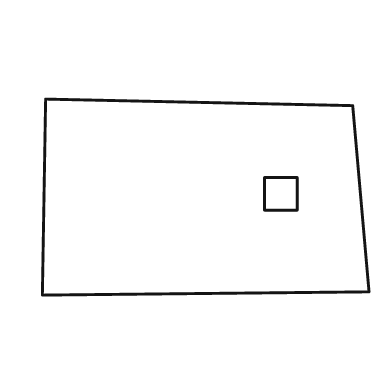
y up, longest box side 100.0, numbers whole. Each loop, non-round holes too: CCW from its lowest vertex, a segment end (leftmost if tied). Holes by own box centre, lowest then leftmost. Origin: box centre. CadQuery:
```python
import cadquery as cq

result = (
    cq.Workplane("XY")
    .moveTo(-50.0, -30.0)
    .lineTo(50.0, -29.0)
    .lineTo(45.0, 28.0)
    .lineTo(-49.0, 30.0)
    .close()
    .moveTo(18.0, -4.0)
    .lineTo(28.0, -4.0)
    .lineTo(28.0, 6.0)
    .lineTo(18.0, 6.0)
    .close()
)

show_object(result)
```